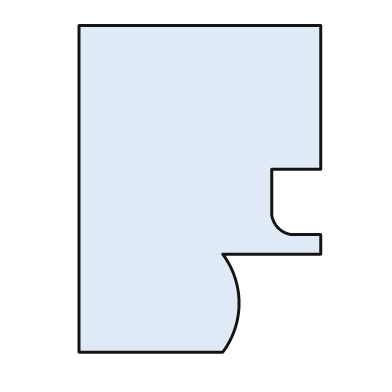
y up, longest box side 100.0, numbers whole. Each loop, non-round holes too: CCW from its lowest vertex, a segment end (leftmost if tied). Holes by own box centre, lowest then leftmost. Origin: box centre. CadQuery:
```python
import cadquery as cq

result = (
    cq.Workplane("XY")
    .moveTo(-37.0, -50.0)
    .lineTo(7.0, -50.0)
    .threePointArc((12.0, -35.0), (7.0, -20.0))
    .lineTo(37.0, -20.0)
    .lineTo(37.0, -14.0)
    .lineTo(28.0, -14.0)
    .threePointArc((24.0, -12.0), (22.0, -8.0))
    .lineTo(22.0, 6.0)
    .lineTo(37.0, 6.0)
    .lineTo(37.0, 50.0)
    .lineTo(-37.0, 50.0)
    .close()
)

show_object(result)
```